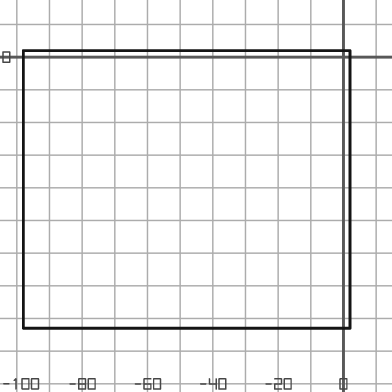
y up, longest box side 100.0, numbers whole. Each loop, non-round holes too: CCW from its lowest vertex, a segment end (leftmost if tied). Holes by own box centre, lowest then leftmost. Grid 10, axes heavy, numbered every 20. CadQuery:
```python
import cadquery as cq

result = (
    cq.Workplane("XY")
    .moveTo(-98.0, -83.0)
    .lineTo(2.0, -83.0)
    .lineTo(2.0, 2.0)
    .lineTo(-98.0, 2.0)
    .close()
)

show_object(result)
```